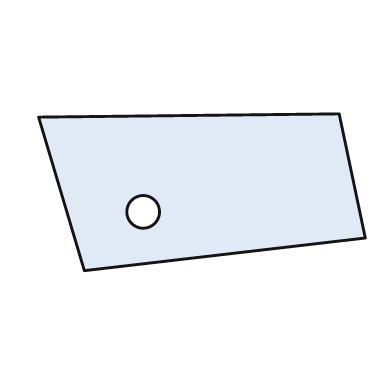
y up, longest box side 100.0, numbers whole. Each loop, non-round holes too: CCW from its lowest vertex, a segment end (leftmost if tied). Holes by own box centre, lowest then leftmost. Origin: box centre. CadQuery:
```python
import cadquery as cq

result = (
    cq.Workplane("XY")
    .moveTo(-36.0, -24.0)
    .lineTo(50.0, -14.0)
    .lineTo(42.0, 24.0)
    .lineTo(-50.0, 23.0)
    .close()
    .moveTo(-18.0, -6.0)
    .circle(5.0)
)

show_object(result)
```